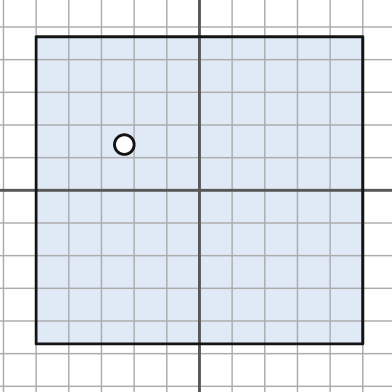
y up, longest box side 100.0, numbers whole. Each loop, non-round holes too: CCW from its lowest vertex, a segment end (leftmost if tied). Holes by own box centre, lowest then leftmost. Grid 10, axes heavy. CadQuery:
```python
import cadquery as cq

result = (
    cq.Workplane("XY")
    .moveTo(-50.0, -47.0)
    .lineTo(50.0, -47.0)
    .lineTo(50.0, 47.0)
    .lineTo(-50.0, 47.0)
    .close()
    .moveTo(-23.0, 14.0)
    .circle(3.0)
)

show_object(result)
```